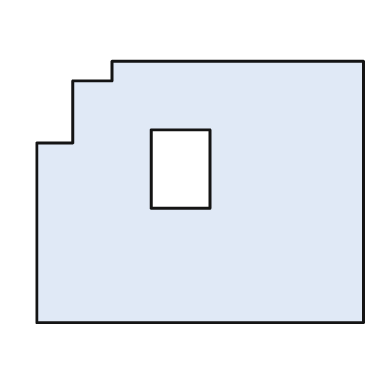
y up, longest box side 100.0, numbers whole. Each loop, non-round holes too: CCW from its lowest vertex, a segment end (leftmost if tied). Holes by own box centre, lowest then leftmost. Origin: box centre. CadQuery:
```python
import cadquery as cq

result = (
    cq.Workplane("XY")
    .moveTo(-50.0, -40.0)
    .lineTo(50.0, -40.0)
    .lineTo(50.0, 40.0)
    .lineTo(-27.0, 40.0)
    .lineTo(-27.0, 34.0)
    .lineTo(-39.0, 34.0)
    .lineTo(-39.0, 15.0)
    .lineTo(-50.0, 15.0)
    .close()
    .moveTo(-15.0, -5.0)
    .lineTo(3.0, -5.0)
    .lineTo(3.0, 19.0)
    .lineTo(-15.0, 19.0)
    .close()
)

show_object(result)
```